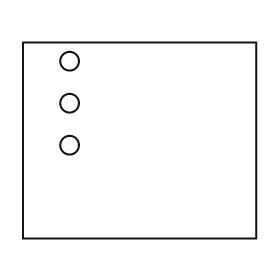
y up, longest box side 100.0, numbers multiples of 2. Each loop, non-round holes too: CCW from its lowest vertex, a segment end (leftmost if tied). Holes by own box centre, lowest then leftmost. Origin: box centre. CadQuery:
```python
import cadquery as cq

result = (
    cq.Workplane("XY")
    .moveTo(-50.0, -42.0)
    .lineTo(50.0, -42.0)
    .lineTo(50.0, 42.0)
    .lineTo(-50.0, 42.0)
    .close()
    .moveTo(-30.0, -2.0)
    .circle(4.0)
    .moveTo(-30.0, 16.0)
    .circle(4.0)
    .moveTo(-30.0, 34.0)
    .circle(4.0)
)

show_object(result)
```